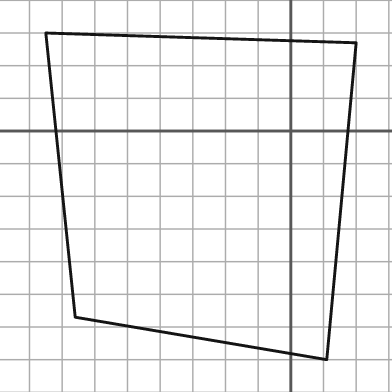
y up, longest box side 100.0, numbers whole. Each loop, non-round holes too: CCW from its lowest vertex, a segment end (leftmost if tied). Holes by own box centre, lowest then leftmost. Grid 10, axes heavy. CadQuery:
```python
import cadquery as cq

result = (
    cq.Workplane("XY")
    .moveTo(11.0, -70.0)
    .lineTo(20.0, 27.0)
    .lineTo(-75.0, 30.0)
    .lineTo(-66.0, -57.0)
    .close()
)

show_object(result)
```